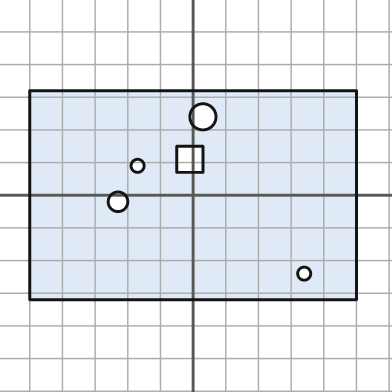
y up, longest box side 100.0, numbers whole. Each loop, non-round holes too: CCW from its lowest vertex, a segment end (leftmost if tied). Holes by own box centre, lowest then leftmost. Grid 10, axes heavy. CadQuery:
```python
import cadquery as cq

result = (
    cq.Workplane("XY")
    .moveTo(-50.0, -32.0)
    .lineTo(50.0, -32.0)
    .lineTo(50.0, 32.0)
    .lineTo(-50.0, 32.0)
    .close()
    .moveTo(34.0, -24.0)
    .circle(2.0)
    .moveTo(-23.0, -2.0)
    .circle(3.0)
    .moveTo(-17.0, 9.0)
    .circle(2.0)
    .moveTo(-5.0, 7.0)
    .lineTo(3.0, 7.0)
    .lineTo(3.0, 15.0)
    .lineTo(-5.0, 15.0)
    .close()
    .moveTo(3.0, 24.0)
    .circle(4.0)
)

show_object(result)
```